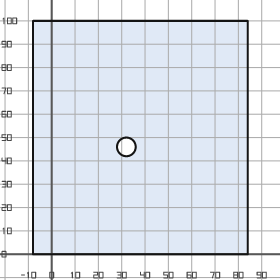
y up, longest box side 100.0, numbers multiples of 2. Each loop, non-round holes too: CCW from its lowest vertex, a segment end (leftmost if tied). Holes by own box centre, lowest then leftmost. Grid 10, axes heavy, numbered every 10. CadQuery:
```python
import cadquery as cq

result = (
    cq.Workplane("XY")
    .moveTo(-8.0, 0.0)
    .lineTo(84.0, 0.0)
    .lineTo(84.0, 100.0)
    .lineTo(-8.0, 100.0)
    .close()
    .moveTo(32.0, 46.0)
    .circle(4.0)
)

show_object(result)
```